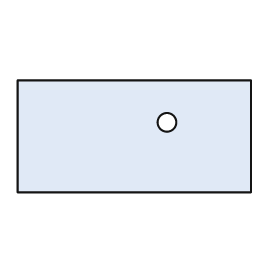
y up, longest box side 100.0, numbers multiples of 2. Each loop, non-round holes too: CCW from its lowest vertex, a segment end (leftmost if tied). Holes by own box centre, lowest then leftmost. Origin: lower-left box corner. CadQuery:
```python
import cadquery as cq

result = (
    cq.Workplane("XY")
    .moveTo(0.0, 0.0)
    .lineTo(100.0, 0.0)
    .lineTo(100.0, 48.0)
    .lineTo(0.0, 48.0)
    .close()
    .moveTo(64.0, 30.0)
    .circle(4.0)
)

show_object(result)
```